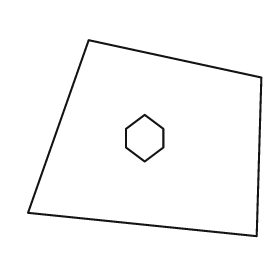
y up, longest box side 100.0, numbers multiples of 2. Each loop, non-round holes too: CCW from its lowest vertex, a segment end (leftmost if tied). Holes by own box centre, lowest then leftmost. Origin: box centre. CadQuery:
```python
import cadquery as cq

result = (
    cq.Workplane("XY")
    .moveTo(48.0, -42.0)
    .lineTo(50.0, 26.0)
    .lineTo(-24.0, 42.0)
    .lineTo(-50.0, -32.0)
    .close()
    .moveTo(0.0, -10.0)
    .lineTo(8.0, -4.0)
    .lineTo(8.0, 4.0)
    .lineTo(0.0, 10.0)
    .lineTo(-8.0, 4.0)
    .lineTo(-8.0, -4.0)
    .close()
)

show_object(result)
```